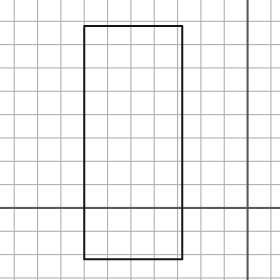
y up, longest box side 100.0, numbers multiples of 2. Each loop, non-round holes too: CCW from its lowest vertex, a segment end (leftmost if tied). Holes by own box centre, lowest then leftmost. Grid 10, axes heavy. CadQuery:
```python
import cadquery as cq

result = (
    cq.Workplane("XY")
    .moveTo(-70.0, -22.0)
    .lineTo(-28.0, -22.0)
    .lineTo(-28.0, 78.0)
    .lineTo(-70.0, 78.0)
    .close()
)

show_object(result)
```